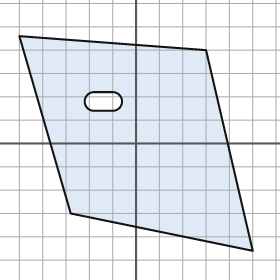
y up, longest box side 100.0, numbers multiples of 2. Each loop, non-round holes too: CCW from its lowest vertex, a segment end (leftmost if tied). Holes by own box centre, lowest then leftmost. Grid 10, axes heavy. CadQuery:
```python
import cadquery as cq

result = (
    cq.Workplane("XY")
    .moveTo(50.0, -46.0)
    .lineTo(30.0, 40.0)
    .lineTo(-50.0, 46.0)
    .lineTo(-28.0, -30.0)
    .close()
    .moveTo(-18.0, 14.0)
    .lineTo(-10.0, 14.0)
    .threePointArc((-6.0, 18.0), (-10.0, 22.0))
    .lineTo(-18.0, 22.0)
    .threePointArc((-22.0, 18.0), (-18.0, 14.0))
    .close()
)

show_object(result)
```